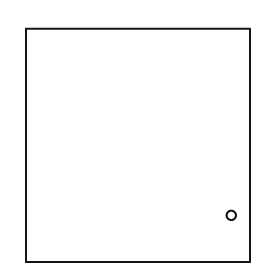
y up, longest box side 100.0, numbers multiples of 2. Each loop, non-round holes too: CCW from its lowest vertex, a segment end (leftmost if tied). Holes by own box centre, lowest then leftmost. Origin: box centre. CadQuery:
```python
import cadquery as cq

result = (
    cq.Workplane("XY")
    .moveTo(-48.0, -50.0)
    .lineTo(48.0, -50.0)
    .lineTo(48.0, 50.0)
    .lineTo(-48.0, 50.0)
    .close()
    .moveTo(40.0, -30.0)
    .circle(2.0)
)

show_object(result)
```